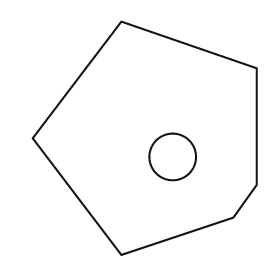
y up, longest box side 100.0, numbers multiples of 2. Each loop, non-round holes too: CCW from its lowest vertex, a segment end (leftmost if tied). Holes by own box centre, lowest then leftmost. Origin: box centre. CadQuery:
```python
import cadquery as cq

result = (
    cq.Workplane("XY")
    .moveTo(-10.0, -50.0)
    .lineTo(38.0, -34.0)
    .lineTo(48.0, -20.0)
    .lineTo(48.0, 30.0)
    .lineTo(-10.0, 50.0)
    .lineTo(-48.0, 0.0)
    .close()
    .moveTo(12.0, -8.0)
    .circle(10.0)
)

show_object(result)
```